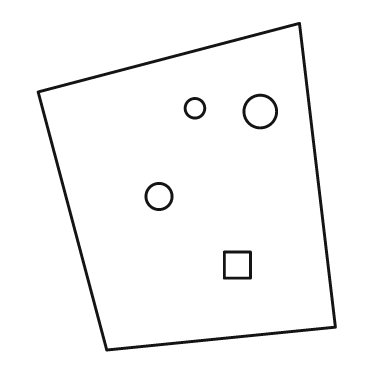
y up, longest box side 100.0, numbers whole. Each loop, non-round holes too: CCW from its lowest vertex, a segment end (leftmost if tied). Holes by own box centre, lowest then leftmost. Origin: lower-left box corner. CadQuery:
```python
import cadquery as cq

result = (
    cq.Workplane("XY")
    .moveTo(21.0, 0.0)
    .lineTo(91.0, 7.0)
    .lineTo(80.0, 100.0)
    .lineTo(0.0, 79.0)
    .close()
    .moveTo(57.0, 22.0)
    .lineTo(65.0, 22.0)
    .lineTo(65.0, 30.0)
    .lineTo(57.0, 30.0)
    .close()
    .moveTo(37.0, 47.0)
    .circle(4.0)
    .moveTo(68.0, 73.0)
    .circle(5.0)
    .moveTo(48.0, 74.0)
    .circle(3.0)
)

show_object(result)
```